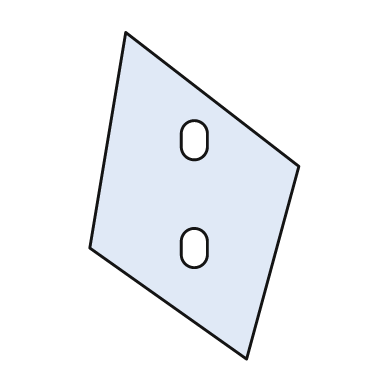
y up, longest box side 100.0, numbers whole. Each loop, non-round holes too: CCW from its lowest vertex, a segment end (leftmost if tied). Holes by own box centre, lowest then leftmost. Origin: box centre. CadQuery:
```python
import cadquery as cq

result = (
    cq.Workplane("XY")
    .moveTo(16.0, -50.0)
    .lineTo(32.0, 9.0)
    .lineTo(-21.0, 50.0)
    .lineTo(-32.0, -16.0)
    .close()
    .moveTo(-4.0, -18.0)
    .threePointArc((0.0, -22.0), (4.0, -18.0))
    .lineTo(4.0, -14.0)
    .threePointArc((0.0, -10.0), (-4.0, -14.0))
    .close()
    .moveTo(-4.0, 15.0)
    .threePointArc((0.0, 11.0), (4.0, 15.0))
    .lineTo(4.0, 19.0)
    .threePointArc((0.0, 23.0), (-4.0, 19.0))
    .close()
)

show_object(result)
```